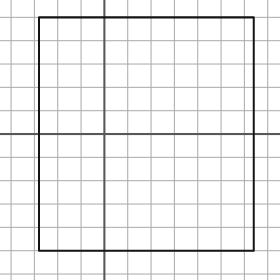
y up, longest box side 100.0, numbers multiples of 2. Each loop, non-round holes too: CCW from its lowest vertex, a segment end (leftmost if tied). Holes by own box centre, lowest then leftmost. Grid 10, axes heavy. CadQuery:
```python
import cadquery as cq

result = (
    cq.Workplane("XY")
    .moveTo(-28.0, -50.0)
    .lineTo(64.0, -50.0)
    .lineTo(64.0, 50.0)
    .lineTo(-28.0, 50.0)
    .close()
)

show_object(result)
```